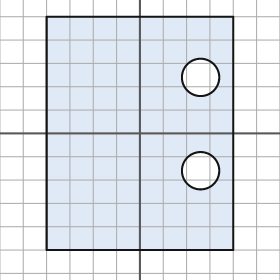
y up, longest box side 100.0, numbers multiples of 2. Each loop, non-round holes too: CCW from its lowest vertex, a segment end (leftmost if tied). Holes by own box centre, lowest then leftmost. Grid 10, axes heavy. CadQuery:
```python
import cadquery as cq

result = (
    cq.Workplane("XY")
    .moveTo(-40.0, -50.0)
    .lineTo(40.0, -50.0)
    .lineTo(40.0, 50.0)
    .lineTo(-40.0, 50.0)
    .close()
    .moveTo(26.0, -16.0)
    .circle(8.0)
    .moveTo(26.0, 24.0)
    .circle(8.0)
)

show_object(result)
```